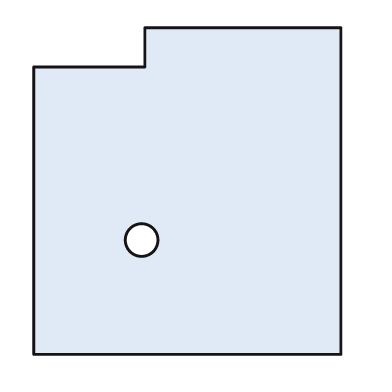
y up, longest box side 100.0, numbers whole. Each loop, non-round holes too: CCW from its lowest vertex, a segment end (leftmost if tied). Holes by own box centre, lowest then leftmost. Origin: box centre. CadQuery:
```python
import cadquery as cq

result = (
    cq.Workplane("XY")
    .moveTo(-47.0, -50.0)
    .lineTo(47.0, -50.0)
    .lineTo(47.0, 50.0)
    .lineTo(-13.0, 50.0)
    .lineTo(-13.0, 38.0)
    .lineTo(-47.0, 38.0)
    .close()
    .moveTo(-14.0, -15.0)
    .circle(5.0)
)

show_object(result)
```